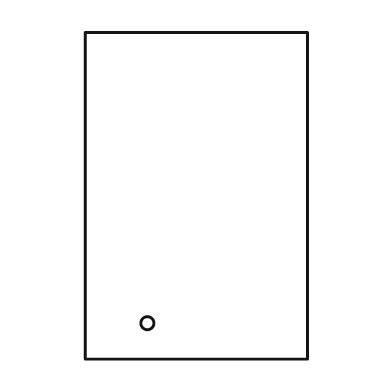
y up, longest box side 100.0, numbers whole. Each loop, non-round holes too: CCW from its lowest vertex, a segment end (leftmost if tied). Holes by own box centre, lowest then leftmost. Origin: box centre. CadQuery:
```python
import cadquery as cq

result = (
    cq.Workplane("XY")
    .moveTo(-34.0, -50.0)
    .lineTo(34.0, -50.0)
    .lineTo(34.0, 50.0)
    .lineTo(-34.0, 50.0)
    .close()
    .moveTo(-15.0, -39.0)
    .circle(2.0)
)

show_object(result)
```